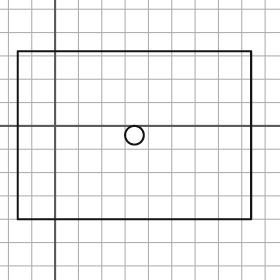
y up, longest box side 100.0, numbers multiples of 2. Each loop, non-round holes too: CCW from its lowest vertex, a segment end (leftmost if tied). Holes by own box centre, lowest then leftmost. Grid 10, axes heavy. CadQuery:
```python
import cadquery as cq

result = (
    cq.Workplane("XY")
    .moveTo(-16.0, -40.0)
    .lineTo(84.0, -40.0)
    .lineTo(84.0, 32.0)
    .lineTo(-16.0, 32.0)
    .close()
    .moveTo(34.0, -4.0)
    .circle(4.0)
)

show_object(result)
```